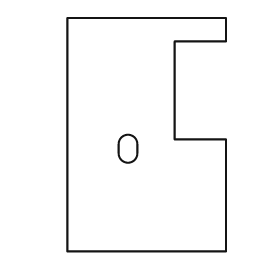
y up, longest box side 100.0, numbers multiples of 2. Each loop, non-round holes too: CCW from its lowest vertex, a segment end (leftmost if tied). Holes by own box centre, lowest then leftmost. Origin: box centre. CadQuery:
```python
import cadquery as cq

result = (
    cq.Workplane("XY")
    .moveTo(-34.0, -50.0)
    .lineTo(34.0, -50.0)
    .lineTo(34.0, -2.0)
    .lineTo(12.0, -2.0)
    .lineTo(12.0, 40.0)
    .lineTo(34.0, 40.0)
    .lineTo(34.0, 50.0)
    .lineTo(-34.0, 50.0)
    .close()
    .moveTo(-12.0, -8.0)
    .threePointArc((-8.0, -12.0), (-4.0, -8.0))
    .lineTo(-4.0, -4.0)
    .threePointArc((-8.0, 0.0), (-12.0, -4.0))
    .close()
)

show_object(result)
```